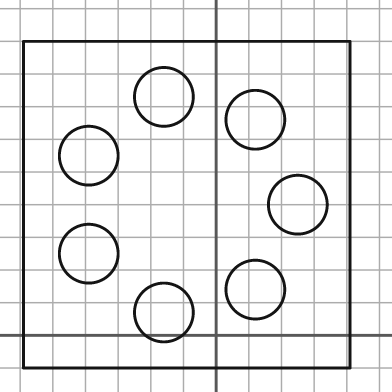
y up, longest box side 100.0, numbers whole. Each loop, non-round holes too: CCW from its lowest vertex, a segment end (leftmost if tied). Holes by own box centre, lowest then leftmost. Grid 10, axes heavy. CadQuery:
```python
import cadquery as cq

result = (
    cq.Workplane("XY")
    .moveTo(-59.0, -10.0)
    .lineTo(41.0, -10.0)
    .lineTo(41.0, 90.0)
    .lineTo(-59.0, 90.0)
    .close()
    .moveTo(-16.0, 7.0)
    .circle(9.0)
    .moveTo(12.0, 14.0)
    .circle(9.0)
    .moveTo(-39.0, 25.0)
    .circle(9.0)
    .moveTo(25.0, 40.0)
    .circle(9.0)
    .moveTo(-39.0, 55.0)
    .circle(9.0)
    .moveTo(12.0, 66.0)
    .circle(9.0)
    .moveTo(-16.0, 73.0)
    .circle(9.0)
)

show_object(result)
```